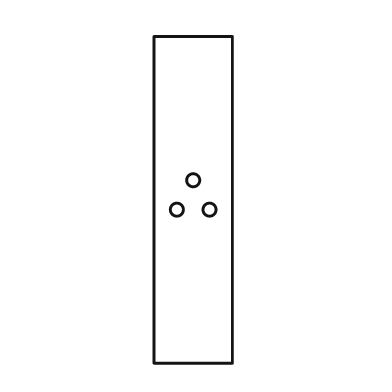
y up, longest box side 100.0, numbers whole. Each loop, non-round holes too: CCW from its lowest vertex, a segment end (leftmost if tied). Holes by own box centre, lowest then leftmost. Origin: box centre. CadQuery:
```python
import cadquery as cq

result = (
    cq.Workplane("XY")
    .moveTo(-12.0, -50.0)
    .lineTo(12.0, -50.0)
    .lineTo(12.0, 50.0)
    .lineTo(-12.0, 50.0)
    .close()
    .moveTo(-5.0, -3.0)
    .circle(2.0)
    .moveTo(5.0, -3.0)
    .circle(2.0)
    .moveTo(0.0, 6.0)
    .circle(2.0)
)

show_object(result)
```